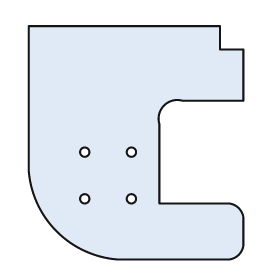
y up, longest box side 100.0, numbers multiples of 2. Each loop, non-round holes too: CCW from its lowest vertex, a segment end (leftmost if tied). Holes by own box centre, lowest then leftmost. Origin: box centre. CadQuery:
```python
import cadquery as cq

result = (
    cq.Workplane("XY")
    .moveTo(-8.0, -50.0)
    .lineTo(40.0, -50.0)
    .threePointArc((44.0, -48.0), (46.0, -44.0))
    .lineTo(46.0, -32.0)
    .threePointArc((44.0, -28.0), (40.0, -26.0))
    .lineTo(10.0, -26.0)
    .lineTo(10.0, 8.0)
    .threePointArc((12.0, 16.0), (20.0, 18.0))
    .lineTo(46.0, 18.0)
    .lineTo(46.0, 40.0)
    .lineTo(36.0, 40.0)
    .lineTo(36.0, 50.0)
    .lineTo(-46.0, 50.0)
    .lineTo(-46.0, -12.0)
    .threePointArc((-34.0, -38.0), (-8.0, -50.0))
    .close()
    .moveTo(-22.0, -24.0)
    .circle(2.0)
    .moveTo(-2.0, -24.0)
    .circle(2.0)
    .moveTo(-22.0, -4.0)
    .circle(2.0)
    .moveTo(-2.0, -4.0)
    .circle(2.0)
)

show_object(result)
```